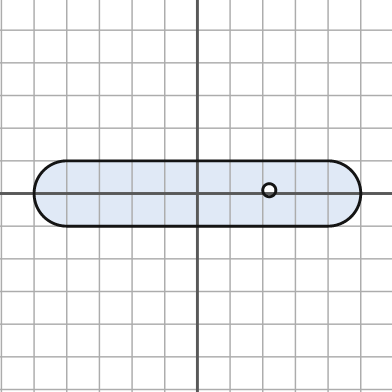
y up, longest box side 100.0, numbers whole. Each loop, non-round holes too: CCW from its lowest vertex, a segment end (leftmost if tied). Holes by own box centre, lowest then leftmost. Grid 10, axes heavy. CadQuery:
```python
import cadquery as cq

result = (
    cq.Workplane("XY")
    .moveTo(-40.0, -10.0)
    .lineTo(40.0, -10.0)
    .threePointArc((50.0, 0.0), (40.0, 10.0))
    .lineTo(-40.0, 10.0)
    .threePointArc((-50.0, 0.0), (-40.0, -10.0))
    .close()
    .moveTo(22.0, 1.0)
    .circle(2.0)
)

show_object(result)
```